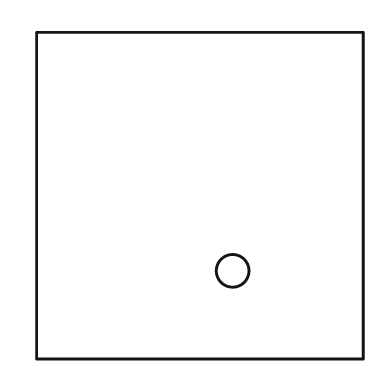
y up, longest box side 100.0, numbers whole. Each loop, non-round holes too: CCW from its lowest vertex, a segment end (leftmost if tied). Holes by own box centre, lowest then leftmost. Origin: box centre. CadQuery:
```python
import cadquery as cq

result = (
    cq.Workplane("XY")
    .moveTo(-50.0, -50.0)
    .lineTo(50.0, -50.0)
    .lineTo(50.0, 50.0)
    .lineTo(-50.0, 50.0)
    .close()
    .moveTo(10.0, -23.0)
    .circle(5.0)
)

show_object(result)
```